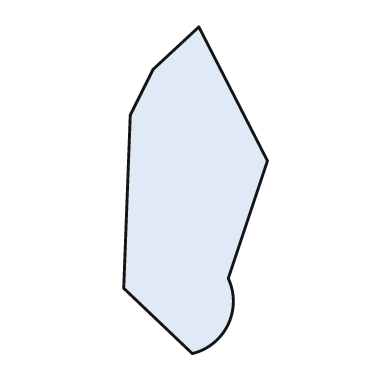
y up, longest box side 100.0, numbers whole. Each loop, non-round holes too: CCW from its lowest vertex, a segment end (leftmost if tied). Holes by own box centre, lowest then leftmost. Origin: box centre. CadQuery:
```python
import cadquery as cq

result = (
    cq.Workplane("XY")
    .moveTo(-1.0, -50.0)
    .threePointArc((10.0, -41.0), (10.0, -27.0))
    .lineTo(22.0, 9.0)
    .lineTo(1.0, 50.0)
    .lineTo(-13.0, 37.0)
    .lineTo(-20.0, 23.0)
    .lineTo(-22.0, -30.0)
    .close()
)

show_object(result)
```